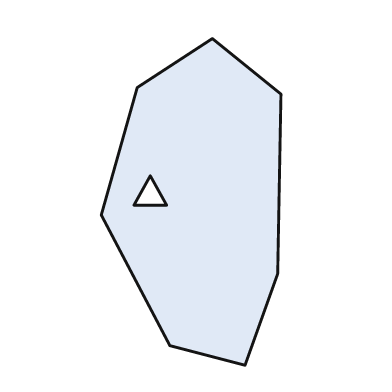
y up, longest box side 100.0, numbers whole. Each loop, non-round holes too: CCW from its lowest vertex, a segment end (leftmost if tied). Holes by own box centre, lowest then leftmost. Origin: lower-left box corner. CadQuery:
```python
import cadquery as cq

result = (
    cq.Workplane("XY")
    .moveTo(44.0, 0.0)
    .lineTo(54.0, 28.0)
    .lineTo(55.0, 83.0)
    .lineTo(34.0, 100.0)
    .lineTo(11.0, 85.0)
    .lineTo(0.0, 46.0)
    .lineTo(21.0, 6.0)
    .close()
    .moveTo(10.0, 49.0)
    .lineTo(20.0, 49.0)
    .lineTo(15.0, 58.0)
    .close()
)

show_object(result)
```